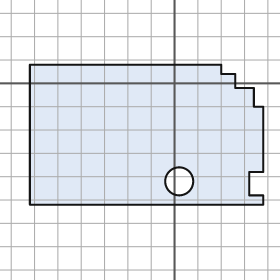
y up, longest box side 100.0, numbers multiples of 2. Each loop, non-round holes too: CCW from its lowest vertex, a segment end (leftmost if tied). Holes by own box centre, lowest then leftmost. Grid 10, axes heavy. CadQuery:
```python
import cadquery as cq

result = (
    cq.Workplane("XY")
    .moveTo(-62.0, -52.0)
    .lineTo(38.0, -52.0)
    .lineTo(38.0, -48.0)
    .lineTo(32.0, -48.0)
    .lineTo(32.0, -38.0)
    .lineTo(38.0, -38.0)
    .lineTo(38.0, -10.0)
    .lineTo(34.0, -10.0)
    .lineTo(34.0, -2.0)
    .lineTo(26.0, -2.0)
    .lineTo(26.0, 4.0)
    .lineTo(20.0, 4.0)
    .lineTo(20.0, 8.0)
    .lineTo(-62.0, 8.0)
    .close()
    .moveTo(2.0, -42.0)
    .circle(6.0)
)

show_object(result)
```